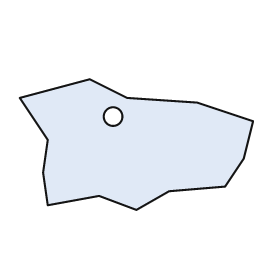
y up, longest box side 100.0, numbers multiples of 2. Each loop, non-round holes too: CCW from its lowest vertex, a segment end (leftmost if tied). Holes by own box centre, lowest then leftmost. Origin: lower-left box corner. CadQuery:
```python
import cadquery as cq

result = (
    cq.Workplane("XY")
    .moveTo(50.0, 0.0)
    .lineTo(64.0, 8.0)
    .lineTo(88.0, 10.0)
    .lineTo(96.0, 22.0)
    .lineTo(100.0, 38.0)
    .lineTo(76.0, 46.0)
    .lineTo(46.0, 48.0)
    .lineTo(30.0, 56.0)
    .lineTo(0.0, 48.0)
    .lineTo(12.0, 30.0)
    .lineTo(10.0, 16.0)
    .lineTo(12.0, 2.0)
    .lineTo(34.0, 6.0)
    .close()
    .moveTo(40.0, 40.0)
    .circle(4.0)
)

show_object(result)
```